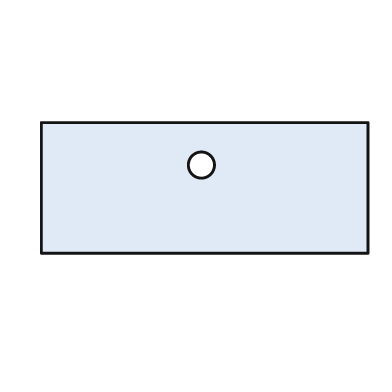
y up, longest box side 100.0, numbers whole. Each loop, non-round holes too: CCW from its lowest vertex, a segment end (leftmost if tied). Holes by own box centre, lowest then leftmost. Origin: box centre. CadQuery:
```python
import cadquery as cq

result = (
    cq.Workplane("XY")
    .moveTo(-50.0, -20.0)
    .lineTo(50.0, -20.0)
    .lineTo(50.0, 20.0)
    .lineTo(-50.0, 20.0)
    .close()
    .moveTo(-1.0, 7.0)
    .circle(4.0)
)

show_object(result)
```